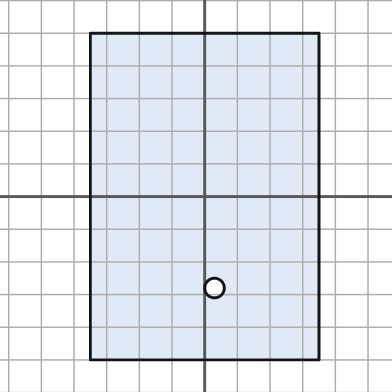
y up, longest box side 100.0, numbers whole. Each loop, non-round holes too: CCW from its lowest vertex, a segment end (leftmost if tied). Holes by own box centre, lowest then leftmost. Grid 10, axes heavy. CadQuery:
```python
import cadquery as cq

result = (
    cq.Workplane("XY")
    .moveTo(-35.0, -50.0)
    .lineTo(35.0, -50.0)
    .lineTo(35.0, 50.0)
    .lineTo(-35.0, 50.0)
    .close()
    .moveTo(3.0, -28.0)
    .circle(3.0)
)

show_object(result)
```